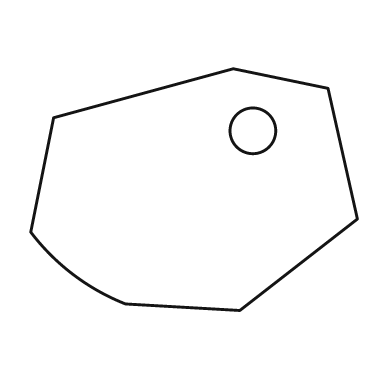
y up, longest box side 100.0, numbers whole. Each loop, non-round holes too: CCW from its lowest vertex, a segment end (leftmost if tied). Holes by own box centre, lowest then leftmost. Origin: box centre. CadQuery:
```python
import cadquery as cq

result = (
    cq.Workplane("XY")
    .moveTo(14.0, -37.0)
    .lineTo(50.0, -9.0)
    .lineTo(41.0, 31.0)
    .lineTo(12.0, 37.0)
    .lineTo(-43.0, 22.0)
    .lineTo(-50.0, -13.0)
    .threePointArc((-37.0, -26.0), (-21.0, -35.0))
    .close()
    .moveTo(18.0, 18.0)
    .circle(7.0)
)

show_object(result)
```